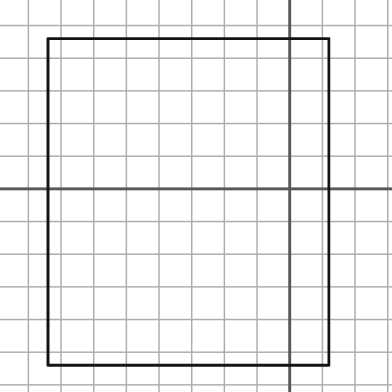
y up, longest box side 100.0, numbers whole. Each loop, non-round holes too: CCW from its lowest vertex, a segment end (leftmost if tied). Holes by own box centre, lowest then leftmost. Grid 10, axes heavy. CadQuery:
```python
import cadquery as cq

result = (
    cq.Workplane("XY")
    .moveTo(-74.0, -54.0)
    .lineTo(12.0, -54.0)
    .lineTo(12.0, 46.0)
    .lineTo(-74.0, 46.0)
    .close()
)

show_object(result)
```